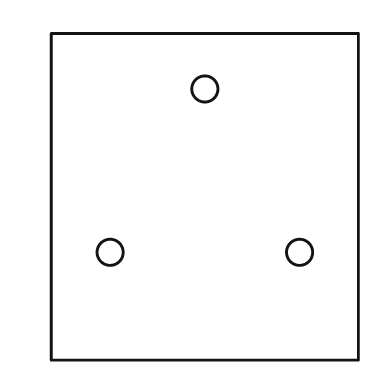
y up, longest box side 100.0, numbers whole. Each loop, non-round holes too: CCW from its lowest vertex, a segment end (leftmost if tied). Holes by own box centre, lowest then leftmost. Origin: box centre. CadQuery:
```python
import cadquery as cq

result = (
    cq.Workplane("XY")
    .moveTo(-47.0, -50.0)
    .lineTo(47.0, -50.0)
    .lineTo(47.0, 50.0)
    .lineTo(-47.0, 50.0)
    .close()
    .moveTo(-29.0, -17.0)
    .circle(4.0)
    .moveTo(29.0, -17.0)
    .circle(4.0)
    .moveTo(0.0, 33.0)
    .circle(4.0)
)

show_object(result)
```